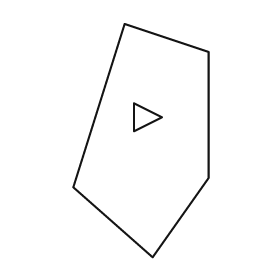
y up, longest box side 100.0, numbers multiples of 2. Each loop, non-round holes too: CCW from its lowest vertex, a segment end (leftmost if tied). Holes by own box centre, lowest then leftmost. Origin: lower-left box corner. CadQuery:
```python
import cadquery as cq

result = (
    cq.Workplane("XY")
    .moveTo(34.0, 0.0)
    .lineTo(58.0, 34.0)
    .lineTo(58.0, 88.0)
    .lineTo(22.0, 100.0)
    .lineTo(0.0, 30.0)
    .close()
    .moveTo(26.0, 54.0)
    .lineTo(38.0, 60.0)
    .lineTo(26.0, 66.0)
    .close()
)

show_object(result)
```